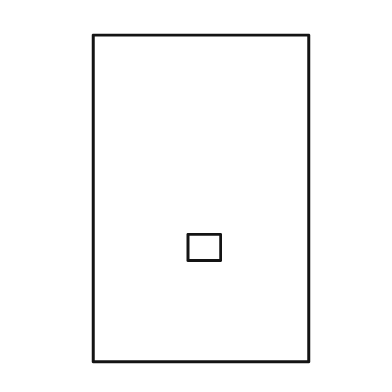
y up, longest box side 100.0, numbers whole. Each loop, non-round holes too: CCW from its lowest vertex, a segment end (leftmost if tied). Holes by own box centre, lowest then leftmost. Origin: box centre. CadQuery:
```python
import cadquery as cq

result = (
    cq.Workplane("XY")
    .moveTo(-33.0, -50.0)
    .lineTo(33.0, -50.0)
    .lineTo(33.0, 50.0)
    .lineTo(-33.0, 50.0)
    .close()
    .moveTo(-4.0, -19.0)
    .lineTo(6.0, -19.0)
    .lineTo(6.0, -11.0)
    .lineTo(-4.0, -11.0)
    .close()
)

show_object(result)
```